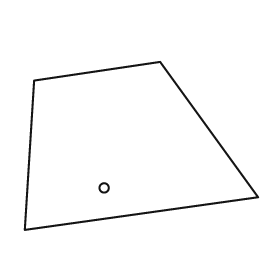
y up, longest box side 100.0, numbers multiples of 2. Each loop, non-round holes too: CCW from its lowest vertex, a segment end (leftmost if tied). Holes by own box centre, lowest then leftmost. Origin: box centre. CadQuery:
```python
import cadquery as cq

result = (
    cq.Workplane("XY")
    .moveTo(-50.0, -36.0)
    .lineTo(50.0, -22.0)
    .lineTo(8.0, 36.0)
    .lineTo(-46.0, 28.0)
    .close()
    .moveTo(-16.0, -18.0)
    .circle(2.0)
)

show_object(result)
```